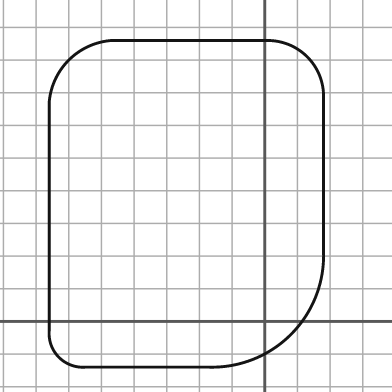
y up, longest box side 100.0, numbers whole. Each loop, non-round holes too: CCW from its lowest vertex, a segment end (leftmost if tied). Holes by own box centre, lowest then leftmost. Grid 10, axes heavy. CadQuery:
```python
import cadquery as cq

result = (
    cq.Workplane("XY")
    .moveTo(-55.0, -14.0)
    .lineTo(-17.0, -14.0)
    .threePointArc((8.0, -4.0), (18.0, 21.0))
    .lineTo(18.0, 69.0)
    .threePointArc((13.0, 81.0), (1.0, 86.0))
    .lineTo(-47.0, 86.0)
    .threePointArc((-60.0, 80.0), (-66.0, 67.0))
    .lineTo(-66.0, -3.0)
    .threePointArc((-63.0, -11.0), (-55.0, -14.0))
    .close()
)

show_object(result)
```